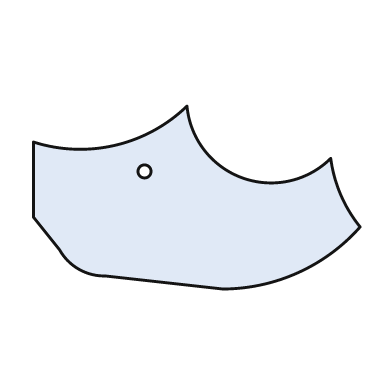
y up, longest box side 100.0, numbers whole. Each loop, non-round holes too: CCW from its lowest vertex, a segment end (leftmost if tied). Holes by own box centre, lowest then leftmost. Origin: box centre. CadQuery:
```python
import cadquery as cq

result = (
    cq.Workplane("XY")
    .moveTo(8.0, -28.0)
    .threePointArc((31.0, -23.0), (50.0, -9.0))
    .threePointArc((44.0, 1.0), (41.0, 12.0))
    .threePointArc((14.0, 6.0), (-3.0, 28.0))
    .threePointArc((-25.0, 16.0), (-50.0, 17.0))
    .lineTo(-50.0, -6.0)
    .lineTo(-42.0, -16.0)
    .threePointArc((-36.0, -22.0), (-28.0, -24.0))
    .close()
    .moveTo(-16.0, 8.0)
    .circle(2.0)
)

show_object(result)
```